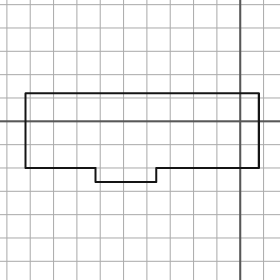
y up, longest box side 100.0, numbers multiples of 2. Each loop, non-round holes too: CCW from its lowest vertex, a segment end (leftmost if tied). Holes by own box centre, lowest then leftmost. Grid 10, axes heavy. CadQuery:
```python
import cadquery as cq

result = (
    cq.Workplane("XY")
    .moveTo(-62.0, -26.0)
    .lineTo(-36.0, -26.0)
    .lineTo(-36.0, -20.0)
    .lineTo(8.0, -20.0)
    .lineTo(8.0, 12.0)
    .lineTo(-92.0, 12.0)
    .lineTo(-92.0, -20.0)
    .lineTo(-62.0, -20.0)
    .close()
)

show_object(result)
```